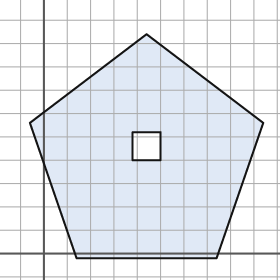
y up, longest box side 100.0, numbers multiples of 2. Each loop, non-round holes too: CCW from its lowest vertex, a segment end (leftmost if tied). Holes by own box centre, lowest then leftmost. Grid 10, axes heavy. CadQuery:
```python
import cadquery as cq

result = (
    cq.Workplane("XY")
    .moveTo(14.0, -2.0)
    .lineTo(74.0, -2.0)
    .lineTo(94.0, 56.0)
    .lineTo(44.0, 94.0)
    .lineTo(-6.0, 56.0)
    .close()
    .moveTo(38.0, 40.0)
    .lineTo(50.0, 40.0)
    .lineTo(50.0, 52.0)
    .lineTo(38.0, 52.0)
    .close()
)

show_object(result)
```